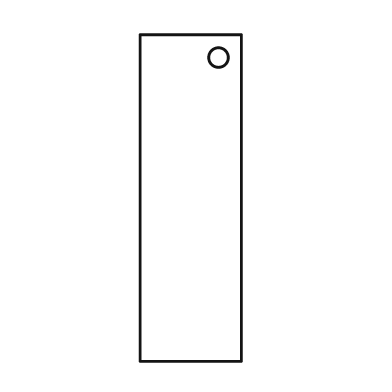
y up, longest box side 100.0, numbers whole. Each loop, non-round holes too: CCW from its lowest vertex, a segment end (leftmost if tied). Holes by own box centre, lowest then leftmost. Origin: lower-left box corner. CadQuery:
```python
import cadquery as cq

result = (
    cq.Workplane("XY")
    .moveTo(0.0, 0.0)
    .lineTo(31.0, 0.0)
    .lineTo(31.0, 100.0)
    .lineTo(0.0, 100.0)
    .close()
    .moveTo(24.0, 93.0)
    .circle(3.0)
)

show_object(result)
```